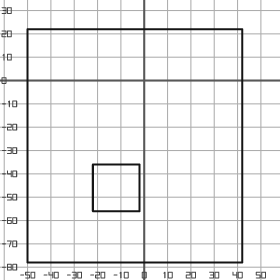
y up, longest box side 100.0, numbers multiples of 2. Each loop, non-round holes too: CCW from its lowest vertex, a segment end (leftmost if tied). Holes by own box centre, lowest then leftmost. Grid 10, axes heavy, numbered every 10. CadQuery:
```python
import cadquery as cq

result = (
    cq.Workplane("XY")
    .moveTo(-50.0, -78.0)
    .lineTo(42.0, -78.0)
    .lineTo(42.0, 22.0)
    .lineTo(-50.0, 22.0)
    .close()
    .moveTo(-22.0, -56.0)
    .lineTo(-2.0, -56.0)
    .lineTo(-2.0, -36.0)
    .lineTo(-22.0, -36.0)
    .close()
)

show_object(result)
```